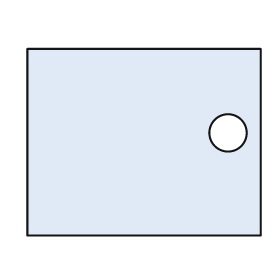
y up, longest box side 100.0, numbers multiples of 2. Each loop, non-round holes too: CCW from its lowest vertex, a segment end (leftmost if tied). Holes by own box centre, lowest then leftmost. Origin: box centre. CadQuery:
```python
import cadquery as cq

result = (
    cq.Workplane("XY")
    .moveTo(-50.0, -40.0)
    .lineTo(50.0, -40.0)
    .lineTo(50.0, 40.0)
    .lineTo(-50.0, 40.0)
    .close()
    .moveTo(36.0, 4.0)
    .circle(8.0)
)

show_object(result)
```